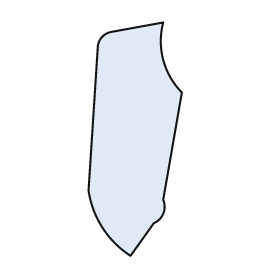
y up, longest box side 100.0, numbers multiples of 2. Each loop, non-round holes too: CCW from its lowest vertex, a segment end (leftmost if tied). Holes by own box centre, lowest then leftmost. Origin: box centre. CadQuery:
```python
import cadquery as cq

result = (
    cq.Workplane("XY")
    .moveTo(-2.0, -50.0)
    .lineTo(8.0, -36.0)
    .threePointArc((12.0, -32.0), (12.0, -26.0))
    .lineTo(20.0, 20.0)
    .threePointArc((12.0, 34.0), (12.0, 50.0))
    .lineTo(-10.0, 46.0)
    .threePointArc((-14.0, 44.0), (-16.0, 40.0))
    .lineTo(-20.0, -22.0)
    .threePointArc((-14.0, -38.0), (-2.0, -50.0))
    .close()
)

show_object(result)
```